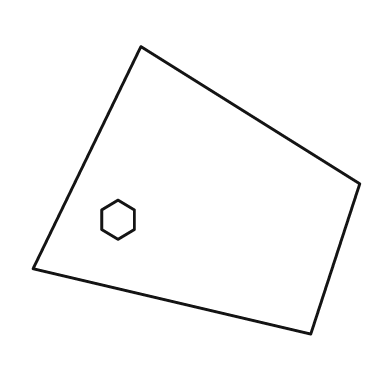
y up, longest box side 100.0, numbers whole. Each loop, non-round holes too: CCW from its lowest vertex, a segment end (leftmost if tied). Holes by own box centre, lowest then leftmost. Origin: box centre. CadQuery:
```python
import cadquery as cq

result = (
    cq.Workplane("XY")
    .moveTo(35.0, -44.0)
    .lineTo(50.0, 2.0)
    .lineTo(-17.0, 44.0)
    .lineTo(-50.0, -24.0)
    .close()
    .moveTo(-24.0, -15.0)
    .lineTo(-19.0, -12.0)
    .lineTo(-19.0, -6.0)
    .lineTo(-24.0, -3.0)
    .lineTo(-29.0, -6.0)
    .lineTo(-29.0, -12.0)
    .close()
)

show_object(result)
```